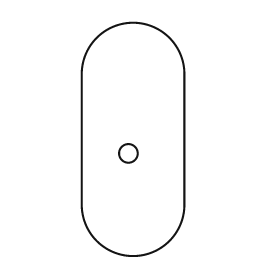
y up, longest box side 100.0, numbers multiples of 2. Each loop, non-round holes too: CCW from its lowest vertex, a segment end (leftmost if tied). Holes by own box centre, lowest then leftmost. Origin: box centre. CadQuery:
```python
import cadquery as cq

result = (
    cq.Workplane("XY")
    .moveTo(-22.0, -28.0)
    .threePointArc((0.0, -50.0), (22.0, -28.0))
    .lineTo(22.0, 28.0)
    .threePointArc((0.0, 50.0), (-22.0, 28.0))
    .close()
    .moveTo(-2.0, -6.0)
    .circle(4.0)
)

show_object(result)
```